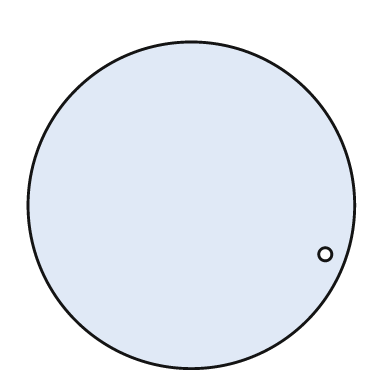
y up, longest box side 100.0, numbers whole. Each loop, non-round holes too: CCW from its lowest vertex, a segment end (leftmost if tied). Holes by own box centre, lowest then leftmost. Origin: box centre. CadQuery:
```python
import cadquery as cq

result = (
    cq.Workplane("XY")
    .moveTo(0.0, 0.0)
    .circle(50.0)
    .moveTo(41.0, -15.0)
    .circle(2.0)
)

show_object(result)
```